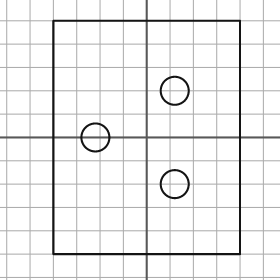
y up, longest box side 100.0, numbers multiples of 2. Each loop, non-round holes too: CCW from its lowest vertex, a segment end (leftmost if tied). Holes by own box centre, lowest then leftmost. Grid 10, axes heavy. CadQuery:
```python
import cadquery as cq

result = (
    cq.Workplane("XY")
    .moveTo(-40.0, -50.0)
    .lineTo(40.0, -50.0)
    .lineTo(40.0, 50.0)
    .lineTo(-40.0, 50.0)
    .close()
    .moveTo(12.0, -20.0)
    .circle(6.0)
    .moveTo(-22.0, 0.0)
    .circle(6.0)
    .moveTo(12.0, 20.0)
    .circle(6.0)
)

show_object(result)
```